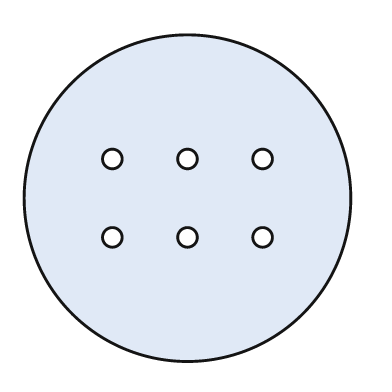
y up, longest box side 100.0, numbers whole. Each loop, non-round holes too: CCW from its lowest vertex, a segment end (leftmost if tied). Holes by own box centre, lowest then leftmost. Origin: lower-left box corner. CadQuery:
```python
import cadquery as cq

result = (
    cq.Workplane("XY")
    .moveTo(50.0, 50.0)
    .circle(50.0)
    .moveTo(27.0, 38.0)
    .circle(3.0)
    .moveTo(50.0, 38.0)
    .circle(3.0)
    .moveTo(73.0, 38.0)
    .circle(3.0)
    .moveTo(27.0, 62.0)
    .circle(3.0)
    .moveTo(50.0, 62.0)
    .circle(3.0)
    .moveTo(73.0, 62.0)
    .circle(3.0)
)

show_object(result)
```